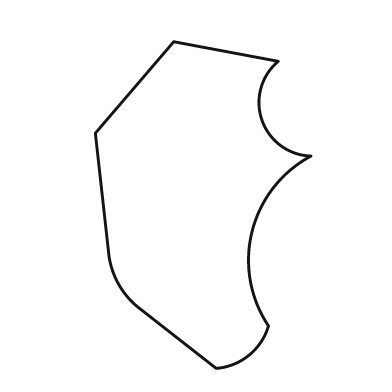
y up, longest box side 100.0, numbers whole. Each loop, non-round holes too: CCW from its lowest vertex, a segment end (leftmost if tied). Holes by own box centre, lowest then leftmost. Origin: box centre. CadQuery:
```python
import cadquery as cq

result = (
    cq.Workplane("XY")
    .moveTo(4.0, -50.0)
    .threePointArc((14.0, -46.0), (20.0, -37.0))
    .threePointArc((15.0, -8.0), (33.0, 15.0))
    .threePointArc((18.0, 26.0), (23.0, 44.0))
    .lineTo(-9.0, 50.0)
    .lineTo(-33.0, 22.0)
    .lineTo(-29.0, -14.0)
    .threePointArc((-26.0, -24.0), (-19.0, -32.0))
    .close()
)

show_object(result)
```